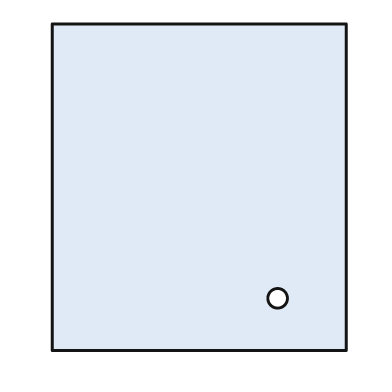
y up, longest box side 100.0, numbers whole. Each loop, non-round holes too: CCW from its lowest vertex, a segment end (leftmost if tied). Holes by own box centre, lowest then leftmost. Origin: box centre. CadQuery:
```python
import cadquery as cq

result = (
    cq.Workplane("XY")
    .moveTo(-45.0, -50.0)
    .lineTo(45.0, -50.0)
    .lineTo(45.0, 50.0)
    .lineTo(-45.0, 50.0)
    .close()
    .moveTo(24.0, -34.0)
    .circle(3.0)
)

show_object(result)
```